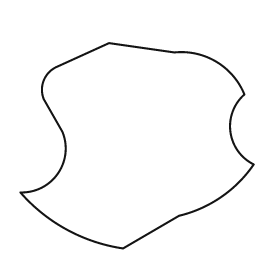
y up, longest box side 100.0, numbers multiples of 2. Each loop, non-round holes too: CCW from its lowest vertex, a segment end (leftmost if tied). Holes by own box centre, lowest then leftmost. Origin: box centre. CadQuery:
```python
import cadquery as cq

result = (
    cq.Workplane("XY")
    .moveTo(-6.0, -44.0)
    .lineTo(18.0, -30.0)
    .threePointArc((36.0, -22.0), (50.0, -8.0))
    .threePointArc((40.0, 6.0), (46.0, 22.0))
    .threePointArc((34.0, 36.0), (16.0, 40.0))
    .lineTo(-12.0, 44.0)
    .lineTo(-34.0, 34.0)
    .threePointArc((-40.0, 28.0), (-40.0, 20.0))
    .lineTo(-32.0, 6.0)
    .threePointArc((-34.0, -12.0), (-50.0, -20.0))
    .threePointArc((-30.0, -36.0), (-6.0, -44.0))
    .close()
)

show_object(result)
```